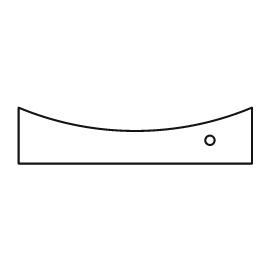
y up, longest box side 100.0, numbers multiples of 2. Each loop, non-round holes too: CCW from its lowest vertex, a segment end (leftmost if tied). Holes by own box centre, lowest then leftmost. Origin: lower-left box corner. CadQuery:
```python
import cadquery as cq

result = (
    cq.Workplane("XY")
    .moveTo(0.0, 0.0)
    .lineTo(100.0, 0.0)
    .lineTo(100.0, 24.0)
    .threePointArc((50.0, 14.0), (0.0, 24.0))
    .close()
    .moveTo(82.0, 10.0)
    .circle(2.0)
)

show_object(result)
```